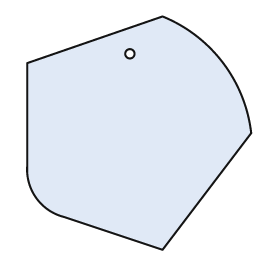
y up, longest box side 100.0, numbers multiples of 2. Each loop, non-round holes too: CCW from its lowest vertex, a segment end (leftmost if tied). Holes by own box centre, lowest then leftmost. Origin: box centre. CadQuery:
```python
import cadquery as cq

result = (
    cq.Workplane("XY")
    .moveTo(10.0, -50.0)
    .lineTo(48.0, 0.0)
    .threePointArc((36.0, 30.0), (10.0, 50.0))
    .lineTo(-48.0, 30.0)
    .lineTo(-48.0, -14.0)
    .threePointArc((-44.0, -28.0), (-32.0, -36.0))
    .close()
    .moveTo(-4.0, 34.0)
    .circle(2.0)
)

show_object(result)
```